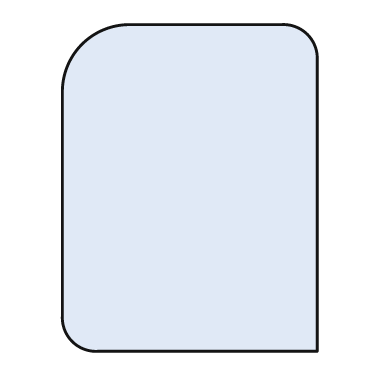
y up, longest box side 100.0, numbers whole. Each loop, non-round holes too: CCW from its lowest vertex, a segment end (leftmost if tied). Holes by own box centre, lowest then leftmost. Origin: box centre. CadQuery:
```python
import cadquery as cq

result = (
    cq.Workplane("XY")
    .moveTo(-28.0, -50.0)
    .lineTo(39.0, -50.0)
    .lineTo(39.0, 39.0)
    .threePointArc((36.0, 47.0), (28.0, 50.0))
    .lineTo(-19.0, 50.0)
    .threePointArc((-33.0, 44.0), (-39.0, 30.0))
    .lineTo(-39.0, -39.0)
    .threePointArc((-36.0, -47.0), (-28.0, -50.0))
    .close()
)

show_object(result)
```